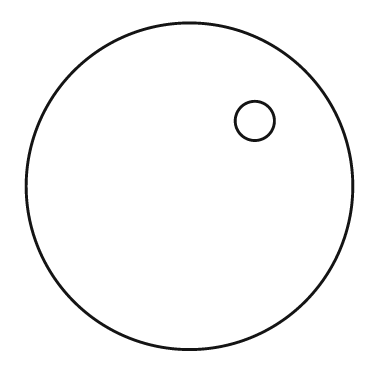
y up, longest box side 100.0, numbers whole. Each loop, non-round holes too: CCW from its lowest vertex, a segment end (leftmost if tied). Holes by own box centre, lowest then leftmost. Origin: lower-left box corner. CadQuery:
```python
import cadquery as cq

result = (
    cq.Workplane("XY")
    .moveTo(50.0, 50.0)
    .circle(50.0)
    .moveTo(70.0, 70.0)
    .circle(6.0)
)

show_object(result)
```